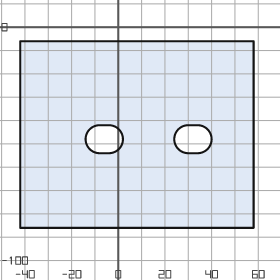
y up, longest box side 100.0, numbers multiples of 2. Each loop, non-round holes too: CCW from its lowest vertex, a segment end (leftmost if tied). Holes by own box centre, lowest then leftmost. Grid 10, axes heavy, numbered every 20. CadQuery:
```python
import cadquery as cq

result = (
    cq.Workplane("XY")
    .moveTo(-42.0, -86.0)
    .lineTo(58.0, -86.0)
    .lineTo(58.0, -6.0)
    .lineTo(-42.0, -6.0)
    .close()
    .moveTo(-8.0, -54.0)
    .lineTo(-4.0, -54.0)
    .threePointArc((2.0, -48.0), (-4.0, -42.0))
    .lineTo(-8.0, -42.0)
    .threePointArc((-14.0, -48.0), (-8.0, -54.0))
    .close()
    .moveTo(30.0, -54.0)
    .lineTo(34.0, -54.0)
    .threePointArc((40.0, -48.0), (34.0, -42.0))
    .lineTo(30.0, -42.0)
    .threePointArc((24.0, -48.0), (30.0, -54.0))
    .close()
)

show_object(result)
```